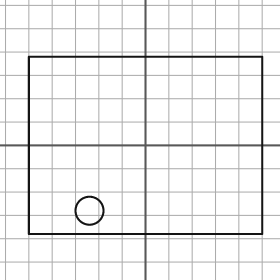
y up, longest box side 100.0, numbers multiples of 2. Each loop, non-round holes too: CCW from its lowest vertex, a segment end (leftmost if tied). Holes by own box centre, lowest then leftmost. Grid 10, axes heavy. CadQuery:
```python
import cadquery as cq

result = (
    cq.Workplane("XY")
    .moveTo(-50.0, -38.0)
    .lineTo(50.0, -38.0)
    .lineTo(50.0, 38.0)
    .lineTo(-50.0, 38.0)
    .close()
    .moveTo(-24.0, -28.0)
    .circle(6.0)
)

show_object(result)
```